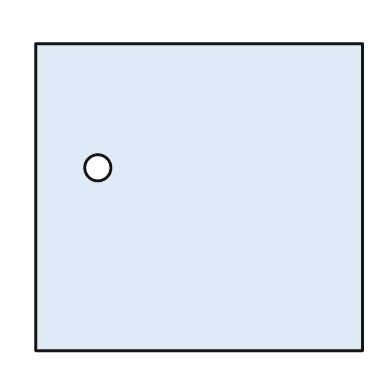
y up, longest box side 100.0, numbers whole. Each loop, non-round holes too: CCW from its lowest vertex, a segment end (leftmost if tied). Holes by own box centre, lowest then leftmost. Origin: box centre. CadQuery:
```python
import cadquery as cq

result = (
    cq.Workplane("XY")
    .moveTo(-50.0, -47.0)
    .lineTo(50.0, -47.0)
    .lineTo(50.0, 47.0)
    .lineTo(-50.0, 47.0)
    .close()
    .moveTo(-31.0, 9.0)
    .circle(4.0)
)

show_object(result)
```